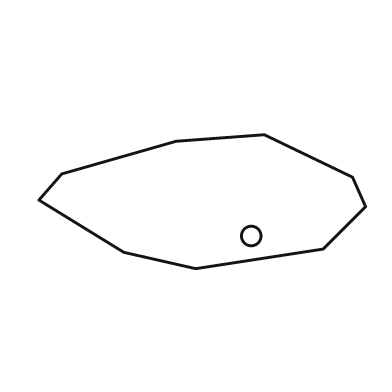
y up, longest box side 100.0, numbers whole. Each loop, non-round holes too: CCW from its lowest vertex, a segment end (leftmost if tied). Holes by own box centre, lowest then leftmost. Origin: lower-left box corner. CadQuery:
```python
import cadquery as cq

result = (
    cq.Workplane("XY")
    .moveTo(48.0, 0.0)
    .lineTo(87.0, 6.0)
    .lineTo(100.0, 19.0)
    .lineTo(96.0, 28.0)
    .lineTo(69.0, 41.0)
    .lineTo(42.0, 39.0)
    .lineTo(7.0, 29.0)
    .lineTo(0.0, 21.0)
    .lineTo(26.0, 5.0)
    .close()
    .moveTo(65.0, 10.0)
    .circle(3.0)
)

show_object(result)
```